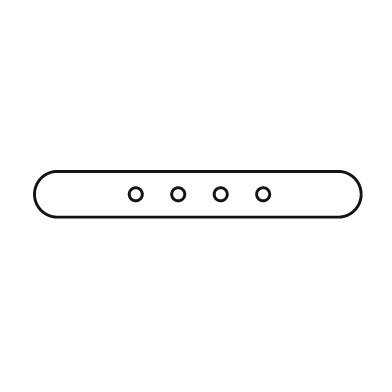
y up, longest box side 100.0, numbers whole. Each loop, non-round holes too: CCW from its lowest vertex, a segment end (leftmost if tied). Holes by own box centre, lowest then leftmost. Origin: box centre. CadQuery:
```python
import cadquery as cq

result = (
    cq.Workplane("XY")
    .moveTo(-43.0, -7.0)
    .lineTo(43.0, -7.0)
    .threePointArc((50.0, 0.0), (43.0, 7.0))
    .lineTo(-43.0, 7.0)
    .threePointArc((-50.0, 0.0), (-43.0, -7.0))
    .close()
    .moveTo(-19.0, 0.0)
    .circle(2.0)
    .moveTo(-6.0, 0.0)
    .circle(2.0)
    .moveTo(7.0, 0.0)
    .circle(2.0)
    .moveTo(20.0, 0.0)
    .circle(2.0)
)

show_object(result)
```